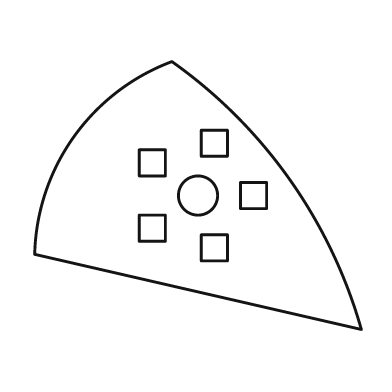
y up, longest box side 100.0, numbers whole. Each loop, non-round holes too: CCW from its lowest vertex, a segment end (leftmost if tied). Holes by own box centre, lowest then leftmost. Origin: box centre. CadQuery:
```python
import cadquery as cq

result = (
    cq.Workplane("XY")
    .moveTo(50.0, -41.0)
    .threePointArc((28.0, 5.0), (-8.0, 41.0))
    .threePointArc((-38.0, 18.0), (-50.0, -18.0))
    .close()
    .moveTo(1.0, -20.0)
    .lineTo(9.0, -20.0)
    .lineTo(9.0, -12.0)
    .lineTo(1.0, -12.0)
    .close()
    .moveTo(-18.0, -14.0)
    .lineTo(-10.0, -14.0)
    .lineTo(-10.0, -6.0)
    .lineTo(-18.0, -6.0)
    .close()
    .moveTo(0.0, 0.0)
    .circle(6.0)
    .moveTo(13.0, -4.0)
    .lineTo(21.0, -4.0)
    .lineTo(21.0, 4.0)
    .lineTo(13.0, 4.0)
    .close()
    .moveTo(-18.0, 6.0)
    .lineTo(-10.0, 6.0)
    .lineTo(-10.0, 14.0)
    .lineTo(-18.0, 14.0)
    .close()
    .moveTo(1.0, 12.0)
    .lineTo(9.0, 12.0)
    .lineTo(9.0, 20.0)
    .lineTo(1.0, 20.0)
    .close()
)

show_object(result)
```